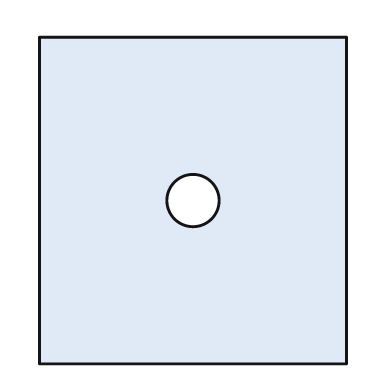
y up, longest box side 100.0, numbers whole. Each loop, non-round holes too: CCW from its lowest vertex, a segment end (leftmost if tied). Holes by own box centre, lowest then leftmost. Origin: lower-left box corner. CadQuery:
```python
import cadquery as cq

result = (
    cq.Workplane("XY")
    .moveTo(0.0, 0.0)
    .lineTo(94.0, 0.0)
    .lineTo(94.0, 100.0)
    .lineTo(0.0, 100.0)
    .close()
    .moveTo(47.0, 50.0)
    .circle(8.0)
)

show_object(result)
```